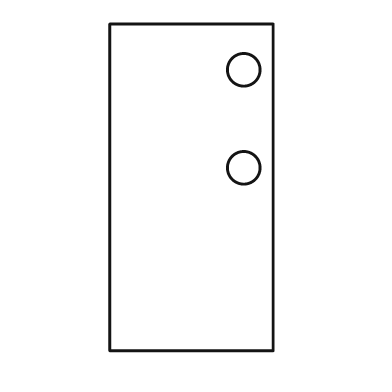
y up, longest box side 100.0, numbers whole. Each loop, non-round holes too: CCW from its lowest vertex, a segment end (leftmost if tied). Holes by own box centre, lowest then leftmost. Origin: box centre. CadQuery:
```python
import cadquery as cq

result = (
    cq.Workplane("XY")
    .moveTo(-25.0, -50.0)
    .lineTo(25.0, -50.0)
    .lineTo(25.0, 50.0)
    .lineTo(-25.0, 50.0)
    .close()
    .moveTo(16.0, 6.0)
    .circle(5.0)
    .moveTo(16.0, 36.0)
    .circle(5.0)
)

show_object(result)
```